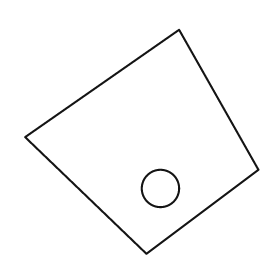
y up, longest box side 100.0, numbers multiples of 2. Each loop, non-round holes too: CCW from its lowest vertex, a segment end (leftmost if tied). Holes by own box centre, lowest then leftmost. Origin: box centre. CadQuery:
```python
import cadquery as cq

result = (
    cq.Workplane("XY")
    .moveTo(2.0, -48.0)
    .lineTo(50.0, -12.0)
    .lineTo(16.0, 48.0)
    .lineTo(-50.0, 2.0)
    .close()
    .moveTo(8.0, -20.0)
    .circle(8.0)
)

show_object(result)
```